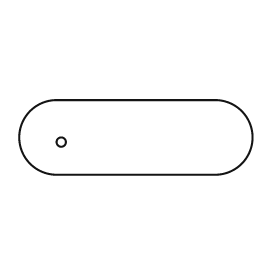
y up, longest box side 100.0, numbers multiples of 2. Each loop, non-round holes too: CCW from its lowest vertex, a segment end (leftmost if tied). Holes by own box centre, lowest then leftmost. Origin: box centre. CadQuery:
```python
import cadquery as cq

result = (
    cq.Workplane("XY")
    .moveTo(-34.0, -16.0)
    .lineTo(34.0, -16.0)
    .threePointArc((50.0, 0.0), (34.0, 16.0))
    .lineTo(-34.0, 16.0)
    .threePointArc((-50.0, 0.0), (-34.0, -16.0))
    .close()
    .moveTo(-32.0, -2.0)
    .circle(2.0)
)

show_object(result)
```